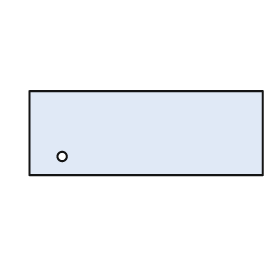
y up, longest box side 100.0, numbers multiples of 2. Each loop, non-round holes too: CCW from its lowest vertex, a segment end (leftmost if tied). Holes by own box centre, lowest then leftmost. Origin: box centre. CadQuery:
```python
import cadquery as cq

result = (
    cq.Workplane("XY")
    .moveTo(-50.0, -18.0)
    .lineTo(50.0, -18.0)
    .lineTo(50.0, 18.0)
    .lineTo(-50.0, 18.0)
    .close()
    .moveTo(-36.0, -10.0)
    .circle(2.0)
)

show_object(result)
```